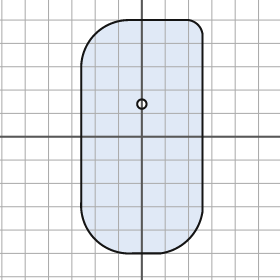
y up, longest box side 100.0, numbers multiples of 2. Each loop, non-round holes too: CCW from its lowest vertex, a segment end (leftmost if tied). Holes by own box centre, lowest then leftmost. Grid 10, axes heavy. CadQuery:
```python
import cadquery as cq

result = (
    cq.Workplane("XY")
    .moveTo(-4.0, -50.0)
    .lineTo(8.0, -50.0)
    .threePointArc((20.0, -44.0), (26.0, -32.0))
    .lineTo(26.0, 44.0)
    .threePointArc((24.0, 48.0), (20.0, 50.0))
    .lineTo(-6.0, 50.0)
    .threePointArc((-20.0, 44.0), (-26.0, 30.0))
    .lineTo(-26.0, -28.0)
    .threePointArc((-20.0, -44.0), (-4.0, -50.0))
    .close()
    .moveTo(0.0, 14.0)
    .circle(2.0)
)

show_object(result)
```